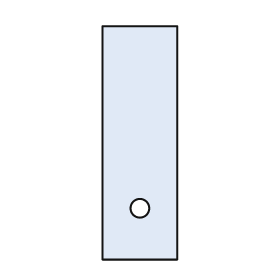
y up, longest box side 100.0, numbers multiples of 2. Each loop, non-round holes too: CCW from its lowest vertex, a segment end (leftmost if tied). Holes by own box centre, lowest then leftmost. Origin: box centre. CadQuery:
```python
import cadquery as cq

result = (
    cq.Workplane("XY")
    .moveTo(-16.0, -50.0)
    .lineTo(16.0, -50.0)
    .lineTo(16.0, 50.0)
    .lineTo(-16.0, 50.0)
    .close()
    .moveTo(0.0, -28.0)
    .circle(4.0)
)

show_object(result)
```